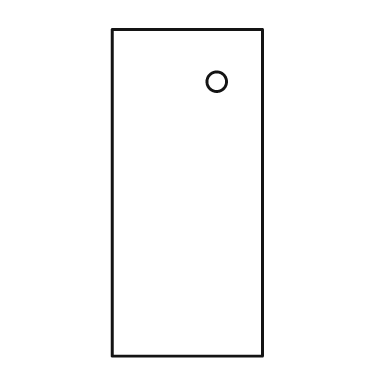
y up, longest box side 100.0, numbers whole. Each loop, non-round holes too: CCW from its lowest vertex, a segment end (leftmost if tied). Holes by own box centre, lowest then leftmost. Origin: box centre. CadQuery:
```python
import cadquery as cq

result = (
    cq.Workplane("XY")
    .moveTo(-23.0, -50.0)
    .lineTo(23.0, -50.0)
    .lineTo(23.0, 50.0)
    .lineTo(-23.0, 50.0)
    .close()
    .moveTo(9.0, 34.0)
    .circle(3.0)
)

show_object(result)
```